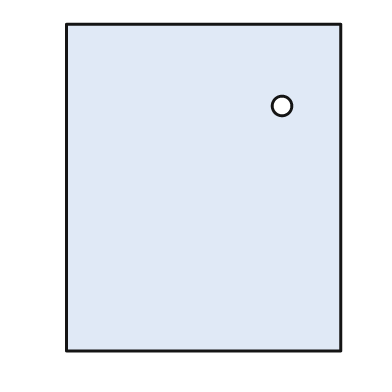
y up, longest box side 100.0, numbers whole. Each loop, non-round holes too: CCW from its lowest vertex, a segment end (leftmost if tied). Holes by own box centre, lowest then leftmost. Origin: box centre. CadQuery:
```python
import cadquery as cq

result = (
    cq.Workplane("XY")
    .moveTo(-42.0, -50.0)
    .lineTo(42.0, -50.0)
    .lineTo(42.0, 50.0)
    .lineTo(-42.0, 50.0)
    .close()
    .moveTo(24.0, 25.0)
    .circle(3.0)
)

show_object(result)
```